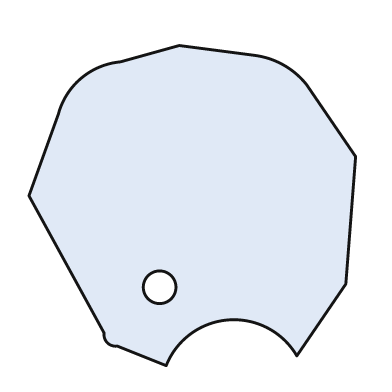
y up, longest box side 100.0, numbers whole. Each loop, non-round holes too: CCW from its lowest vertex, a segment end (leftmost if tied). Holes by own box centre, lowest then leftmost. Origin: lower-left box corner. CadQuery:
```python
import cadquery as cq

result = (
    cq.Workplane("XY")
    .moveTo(42.0, 0.0)
    .threePointArc((61.0, 14.0), (82.0, 3.0))
    .lineTo(97.0, 25.0)
    .lineTo(100.0, 64.0)
    .lineTo(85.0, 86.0)
    .threePointArc((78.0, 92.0), (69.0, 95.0))
    .lineTo(46.0, 98.0)
    .lineTo(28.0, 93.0)
    .threePointArc((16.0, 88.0), (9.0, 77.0))
    .lineTo(0.0, 52.0)
    .lineTo(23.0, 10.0)
    .threePointArc((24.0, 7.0), (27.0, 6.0))
    .close()
    .moveTo(40.0, 24.0)
    .circle(5.0)
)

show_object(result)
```